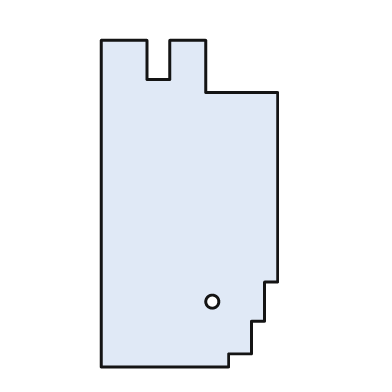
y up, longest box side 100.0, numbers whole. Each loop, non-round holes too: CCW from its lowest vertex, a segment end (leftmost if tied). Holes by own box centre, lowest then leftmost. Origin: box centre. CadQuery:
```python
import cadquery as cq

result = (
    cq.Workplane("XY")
    .moveTo(-27.0, -50.0)
    .lineTo(12.0, -50.0)
    .lineTo(12.0, -46.0)
    .lineTo(19.0, -46.0)
    .lineTo(19.0, -36.0)
    .lineTo(23.0, -36.0)
    .lineTo(23.0, -24.0)
    .lineTo(27.0, -24.0)
    .lineTo(27.0, 34.0)
    .lineTo(5.0, 34.0)
    .lineTo(5.0, 50.0)
    .lineTo(-6.0, 50.0)
    .lineTo(-6.0, 38.0)
    .lineTo(-13.0, 38.0)
    .lineTo(-13.0, 50.0)
    .lineTo(-27.0, 50.0)
    .close()
    .moveTo(7.0, -30.0)
    .circle(2.0)
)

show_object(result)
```